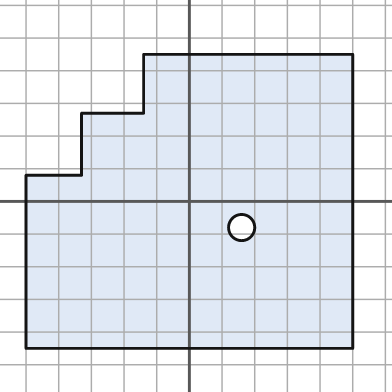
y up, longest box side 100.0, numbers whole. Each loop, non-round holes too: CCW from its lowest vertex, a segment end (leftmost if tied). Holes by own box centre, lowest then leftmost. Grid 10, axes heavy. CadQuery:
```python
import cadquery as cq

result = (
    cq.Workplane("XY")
    .moveTo(-50.0, -45.0)
    .lineTo(50.0, -45.0)
    .lineTo(50.0, 45.0)
    .lineTo(-14.0, 45.0)
    .lineTo(-14.0, 27.0)
    .lineTo(-33.0, 27.0)
    .lineTo(-33.0, 8.0)
    .lineTo(-50.0, 8.0)
    .close()
    .moveTo(16.0, -8.0)
    .circle(4.0)
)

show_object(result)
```